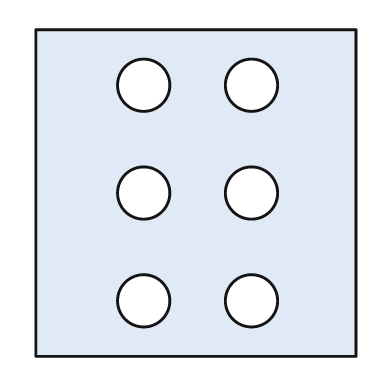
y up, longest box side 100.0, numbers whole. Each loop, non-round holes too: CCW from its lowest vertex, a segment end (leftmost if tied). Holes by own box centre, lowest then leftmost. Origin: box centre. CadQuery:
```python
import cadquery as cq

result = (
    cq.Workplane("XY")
    .moveTo(-49.0, -50.0)
    .lineTo(49.0, -50.0)
    .lineTo(49.0, 50.0)
    .lineTo(-49.0, 50.0)
    .close()
    .moveTo(-16.0, -33.0)
    .circle(8.0)
    .moveTo(17.0, -33.0)
    .circle(8.0)
    .moveTo(-16.0, 0.0)
    .circle(8.0)
    .moveTo(17.0, 0.0)
    .circle(8.0)
    .moveTo(-16.0, 33.0)
    .circle(8.0)
    .moveTo(17.0, 33.0)
    .circle(8.0)
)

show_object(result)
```